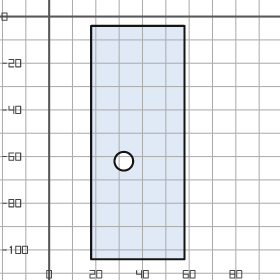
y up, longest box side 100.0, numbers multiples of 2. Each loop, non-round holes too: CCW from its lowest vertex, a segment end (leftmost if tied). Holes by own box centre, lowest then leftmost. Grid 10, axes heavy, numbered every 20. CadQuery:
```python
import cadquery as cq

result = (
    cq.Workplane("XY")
    .moveTo(18.0, -104.0)
    .lineTo(58.0, -104.0)
    .lineTo(58.0, -4.0)
    .lineTo(18.0, -4.0)
    .close()
    .moveTo(32.0, -62.0)
    .circle(4.0)
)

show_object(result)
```